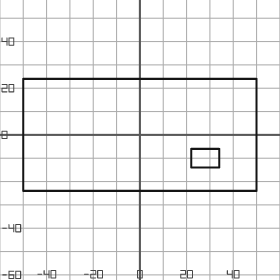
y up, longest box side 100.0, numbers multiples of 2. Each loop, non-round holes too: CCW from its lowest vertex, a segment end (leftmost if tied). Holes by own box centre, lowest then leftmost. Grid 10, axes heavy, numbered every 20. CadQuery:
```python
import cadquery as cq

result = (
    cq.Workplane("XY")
    .moveTo(-50.0, -24.0)
    .lineTo(50.0, -24.0)
    .lineTo(50.0, 24.0)
    .lineTo(-50.0, 24.0)
    .close()
    .moveTo(22.0, -14.0)
    .lineTo(34.0, -14.0)
    .lineTo(34.0, -6.0)
    .lineTo(22.0, -6.0)
    .close()
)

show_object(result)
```